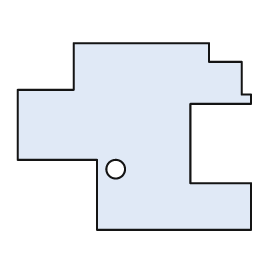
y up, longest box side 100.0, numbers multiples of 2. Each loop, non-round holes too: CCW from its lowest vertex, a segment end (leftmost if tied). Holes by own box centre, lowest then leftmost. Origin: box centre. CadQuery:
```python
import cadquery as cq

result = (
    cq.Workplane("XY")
    .moveTo(-16.0, -40.0)
    .lineTo(50.0, -40.0)
    .lineTo(50.0, -20.0)
    .lineTo(24.0, -20.0)
    .lineTo(24.0, 14.0)
    .lineTo(50.0, 14.0)
    .lineTo(50.0, 18.0)
    .lineTo(46.0, 18.0)
    .lineTo(46.0, 32.0)
    .lineTo(32.0, 32.0)
    .lineTo(32.0, 40.0)
    .lineTo(-26.0, 40.0)
    .lineTo(-26.0, 20.0)
    .lineTo(-50.0, 20.0)
    .lineTo(-50.0, -10.0)
    .lineTo(-16.0, -10.0)
    .close()
    .moveTo(-8.0, -14.0)
    .circle(4.0)
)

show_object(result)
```